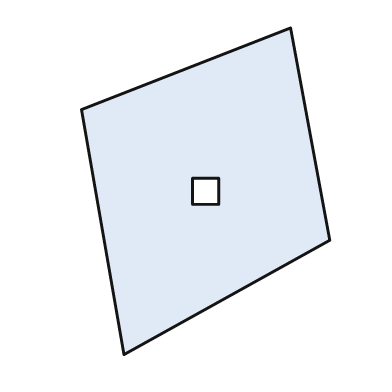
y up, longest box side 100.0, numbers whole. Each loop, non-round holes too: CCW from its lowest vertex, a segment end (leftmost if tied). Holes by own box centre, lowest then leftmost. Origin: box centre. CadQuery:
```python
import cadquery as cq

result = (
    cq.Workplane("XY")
    .moveTo(-25.0, -50.0)
    .lineTo(38.0, -15.0)
    .lineTo(26.0, 50.0)
    .lineTo(-38.0, 25.0)
    .close()
    .moveTo(-4.0, -4.0)
    .lineTo(4.0, -4.0)
    .lineTo(4.0, 4.0)
    .lineTo(-4.0, 4.0)
    .close()
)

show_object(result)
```